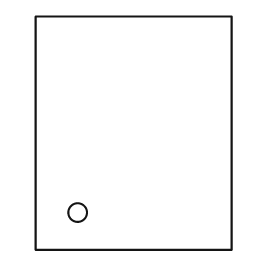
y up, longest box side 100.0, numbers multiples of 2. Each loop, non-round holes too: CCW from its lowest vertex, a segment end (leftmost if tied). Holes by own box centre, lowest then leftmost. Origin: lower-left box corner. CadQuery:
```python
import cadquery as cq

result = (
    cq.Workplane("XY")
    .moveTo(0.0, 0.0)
    .lineTo(84.0, 0.0)
    .lineTo(84.0, 100.0)
    .lineTo(0.0, 100.0)
    .close()
    .moveTo(18.0, 16.0)
    .circle(4.0)
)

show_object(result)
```